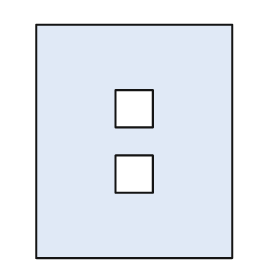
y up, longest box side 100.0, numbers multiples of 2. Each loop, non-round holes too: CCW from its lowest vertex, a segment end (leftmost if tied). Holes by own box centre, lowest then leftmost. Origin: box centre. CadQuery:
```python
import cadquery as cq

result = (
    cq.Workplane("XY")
    .moveTo(-42.0, -50.0)
    .lineTo(42.0, -50.0)
    .lineTo(42.0, 50.0)
    .lineTo(-42.0, 50.0)
    .close()
    .moveTo(-8.0, -22.0)
    .lineTo(8.0, -22.0)
    .lineTo(8.0, -6.0)
    .lineTo(-8.0, -6.0)
    .close()
    .moveTo(-8.0, 6.0)
    .lineTo(8.0, 6.0)
    .lineTo(8.0, 22.0)
    .lineTo(-8.0, 22.0)
    .close()
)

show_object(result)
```